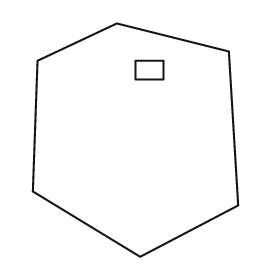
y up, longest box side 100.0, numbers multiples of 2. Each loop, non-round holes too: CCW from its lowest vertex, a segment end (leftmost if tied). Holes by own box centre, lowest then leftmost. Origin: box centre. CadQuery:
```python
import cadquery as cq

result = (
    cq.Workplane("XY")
    .moveTo(2.0, -50.0)
    .lineTo(44.0, -28.0)
    .lineTo(40.0, 38.0)
    .lineTo(-8.0, 50.0)
    .lineTo(-42.0, 34.0)
    .lineTo(-44.0, -22.0)
    .close()
    .moveTo(0.0, 26.0)
    .lineTo(12.0, 26.0)
    .lineTo(12.0, 34.0)
    .lineTo(0.0, 34.0)
    .close()
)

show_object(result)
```